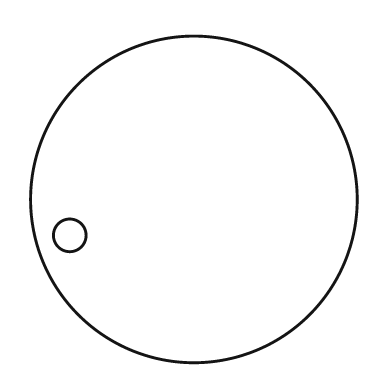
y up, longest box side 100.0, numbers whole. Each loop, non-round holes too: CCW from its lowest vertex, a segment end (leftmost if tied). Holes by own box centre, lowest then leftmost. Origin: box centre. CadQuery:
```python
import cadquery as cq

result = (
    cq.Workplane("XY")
    .moveTo(0.0, 0.0)
    .circle(50.0)
    .moveTo(-38.0, -11.0)
    .circle(5.0)
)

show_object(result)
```